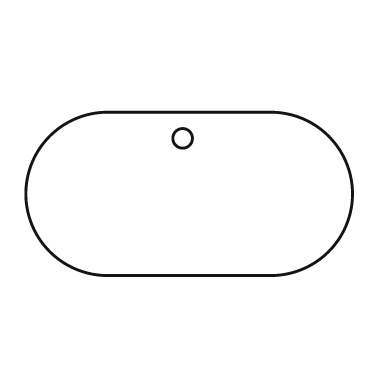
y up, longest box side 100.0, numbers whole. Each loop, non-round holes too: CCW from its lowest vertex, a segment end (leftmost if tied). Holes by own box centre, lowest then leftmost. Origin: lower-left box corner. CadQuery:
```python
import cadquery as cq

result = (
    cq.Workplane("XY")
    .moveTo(25.0, 0.0)
    .lineTo(75.0, 0.0)
    .threePointArc((100.0, 25.0), (75.0, 50.0))
    .lineTo(25.0, 50.0)
    .threePointArc((0.0, 25.0), (25.0, 0.0))
    .close()
    .moveTo(48.0, 42.0)
    .circle(3.0)
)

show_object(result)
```